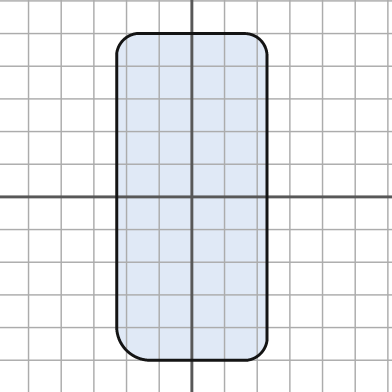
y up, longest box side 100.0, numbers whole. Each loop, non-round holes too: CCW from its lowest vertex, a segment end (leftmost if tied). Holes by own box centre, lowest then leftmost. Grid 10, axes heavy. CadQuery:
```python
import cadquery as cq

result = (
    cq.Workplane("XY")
    .moveTo(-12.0, -50.0)
    .lineTo(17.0, -50.0)
    .threePointArc((21.0, -48.0), (23.0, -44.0))
    .lineTo(23.0, 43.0)
    .threePointArc((21.0, 48.0), (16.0, 50.0))
    .lineTo(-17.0, 50.0)
    .threePointArc((-21.0, 48.0), (-23.0, 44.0))
    .lineTo(-23.0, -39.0)
    .threePointArc((-20.0, -47.0), (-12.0, -50.0))
    .close()
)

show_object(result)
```